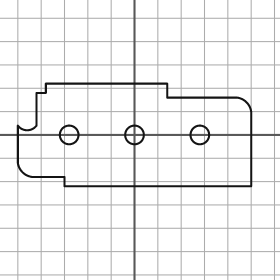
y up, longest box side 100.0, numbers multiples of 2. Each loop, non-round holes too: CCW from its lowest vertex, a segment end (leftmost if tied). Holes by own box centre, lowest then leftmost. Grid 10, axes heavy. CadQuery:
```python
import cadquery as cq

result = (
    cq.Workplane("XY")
    .moveTo(-30.0, -22.0)
    .lineTo(50.0, -22.0)
    .lineTo(50.0, 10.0)
    .threePointArc((48.0, 14.0), (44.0, 16.0))
    .lineTo(14.0, 16.0)
    .lineTo(14.0, 22.0)
    .lineTo(-38.0, 22.0)
    .lineTo(-38.0, 18.0)
    .lineTo(-42.0, 18.0)
    .lineTo(-42.0, 4.0)
    .threePointArc((-46.0, 2.0), (-50.0, 4.0))
    .lineTo(-50.0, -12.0)
    .threePointArc((-48.0, -16.0), (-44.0, -18.0))
    .lineTo(-30.0, -18.0)
    .close()
    .moveTo(-28.0, 0.0)
    .circle(4.0)
    .moveTo(0.0, 0.0)
    .circle(4.0)
    .moveTo(28.0, 0.0)
    .circle(4.0)
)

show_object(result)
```